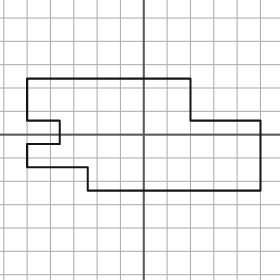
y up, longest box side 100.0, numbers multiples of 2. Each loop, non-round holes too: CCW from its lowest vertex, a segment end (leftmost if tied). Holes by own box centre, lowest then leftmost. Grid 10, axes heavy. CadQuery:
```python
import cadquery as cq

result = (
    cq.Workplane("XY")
    .moveTo(-24.0, -24.0)
    .lineTo(50.0, -24.0)
    .lineTo(50.0, 6.0)
    .lineTo(20.0, 6.0)
    .lineTo(20.0, 24.0)
    .lineTo(-50.0, 24.0)
    .lineTo(-50.0, 6.0)
    .lineTo(-36.0, 6.0)
    .lineTo(-36.0, -4.0)
    .lineTo(-50.0, -4.0)
    .lineTo(-50.0, -14.0)
    .lineTo(-24.0, -14.0)
    .close()
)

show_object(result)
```